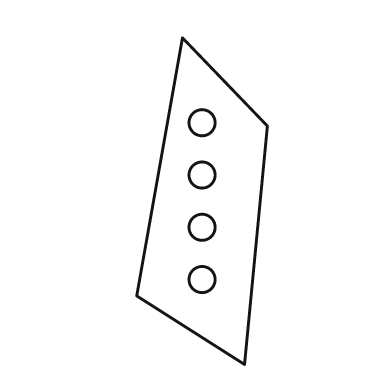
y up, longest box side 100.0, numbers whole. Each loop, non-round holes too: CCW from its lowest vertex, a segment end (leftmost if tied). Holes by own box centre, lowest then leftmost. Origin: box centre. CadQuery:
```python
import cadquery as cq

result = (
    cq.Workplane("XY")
    .moveTo(13.0, -50.0)
    .lineTo(20.0, 23.0)
    .lineTo(-6.0, 50.0)
    .lineTo(-20.0, -29.0)
    .close()
    .moveTo(0.0, -24.0)
    .circle(4.0)
    .moveTo(0.0, -8.0)
    .circle(4.0)
    .moveTo(0.0, 8.0)
    .circle(4.0)
    .moveTo(0.0, 24.0)
    .circle(4.0)
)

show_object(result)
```